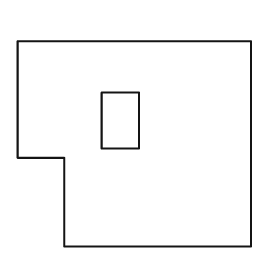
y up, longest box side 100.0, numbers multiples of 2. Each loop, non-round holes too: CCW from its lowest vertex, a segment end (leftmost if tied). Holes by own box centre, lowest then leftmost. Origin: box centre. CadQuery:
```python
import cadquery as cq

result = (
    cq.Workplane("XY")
    .moveTo(-30.0, -44.0)
    .lineTo(50.0, -44.0)
    .lineTo(50.0, 44.0)
    .lineTo(-50.0, 44.0)
    .lineTo(-50.0, -6.0)
    .lineTo(-30.0, -6.0)
    .close()
    .moveTo(-14.0, -2.0)
    .lineTo(2.0, -2.0)
    .lineTo(2.0, 22.0)
    .lineTo(-14.0, 22.0)
    .close()
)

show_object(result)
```